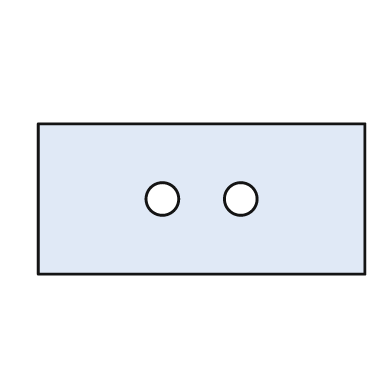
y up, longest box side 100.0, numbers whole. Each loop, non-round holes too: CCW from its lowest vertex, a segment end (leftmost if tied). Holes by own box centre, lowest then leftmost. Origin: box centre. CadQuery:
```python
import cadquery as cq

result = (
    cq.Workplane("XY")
    .moveTo(-50.0, -23.0)
    .lineTo(50.0, -23.0)
    .lineTo(50.0, 23.0)
    .lineTo(-50.0, 23.0)
    .close()
    .moveTo(-12.0, 0.0)
    .circle(5.0)
    .moveTo(12.0, 0.0)
    .circle(5.0)
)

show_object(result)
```